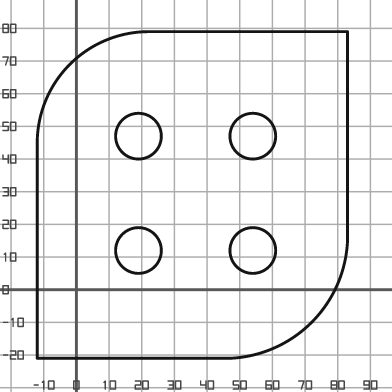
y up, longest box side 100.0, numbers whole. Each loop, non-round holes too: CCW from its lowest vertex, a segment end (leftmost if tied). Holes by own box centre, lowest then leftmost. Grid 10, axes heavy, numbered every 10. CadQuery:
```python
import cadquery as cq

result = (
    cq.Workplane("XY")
    .moveTo(-12.0, -21.0)
    .lineTo(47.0, -21.0)
    .threePointArc((72.0, -10.0), (83.0, 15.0))
    .lineTo(83.0, 79.0)
    .lineTo(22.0, 79.0)
    .threePointArc((-2.0, 69.0), (-12.0, 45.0))
    .close()
    .moveTo(19.0, 12.0)
    .circle(7.0)
    .moveTo(54.0, 12.0)
    .circle(7.0)
    .moveTo(19.0, 47.0)
    .circle(7.0)
    .moveTo(54.0, 47.0)
    .circle(7.0)
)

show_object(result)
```